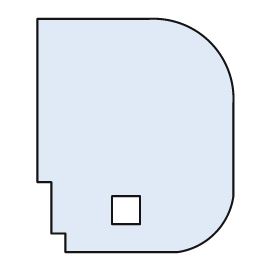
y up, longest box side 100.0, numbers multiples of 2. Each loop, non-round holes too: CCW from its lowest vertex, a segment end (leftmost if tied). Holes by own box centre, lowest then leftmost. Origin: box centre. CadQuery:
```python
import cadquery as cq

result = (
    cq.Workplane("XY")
    .moveTo(-30.0, -50.0)
    .lineTo(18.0, -50.0)
    .threePointArc((34.0, -42.0), (42.0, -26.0))
    .lineTo(42.0, 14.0)
    .threePointArc((32.0, 40.0), (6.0, 50.0))
    .lineTo(-42.0, 50.0)
    .lineTo(-42.0, -20.0)
    .lineTo(-36.0, -20.0)
    .lineTo(-36.0, -42.0)
    .lineTo(-30.0, -42.0)
    .close()
    .moveTo(-10.0, -38.0)
    .lineTo(2.0, -38.0)
    .lineTo(2.0, -26.0)
    .lineTo(-10.0, -26.0)
    .close()
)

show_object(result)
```